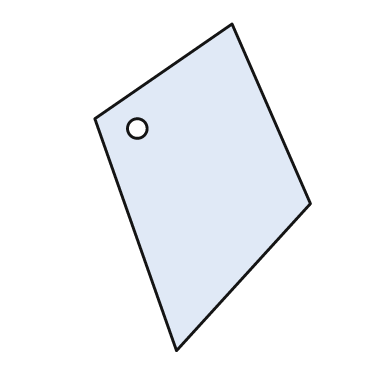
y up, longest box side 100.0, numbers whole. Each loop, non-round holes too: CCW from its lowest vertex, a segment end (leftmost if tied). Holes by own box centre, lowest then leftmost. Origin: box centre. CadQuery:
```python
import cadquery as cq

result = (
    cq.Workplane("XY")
    .moveTo(-8.0, -50.0)
    .lineTo(33.0, -5.0)
    .lineTo(9.0, 50.0)
    .lineTo(-33.0, 21.0)
    .close()
    .moveTo(-20.0, 18.0)
    .circle(3.0)
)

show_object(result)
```